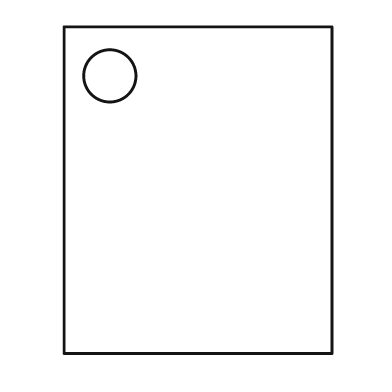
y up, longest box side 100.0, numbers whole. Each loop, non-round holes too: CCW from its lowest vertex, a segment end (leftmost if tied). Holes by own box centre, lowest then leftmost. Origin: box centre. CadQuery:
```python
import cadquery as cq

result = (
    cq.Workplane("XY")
    .moveTo(-41.0, -50.0)
    .lineTo(41.0, -50.0)
    .lineTo(41.0, 50.0)
    .lineTo(-41.0, 50.0)
    .close()
    .moveTo(-27.0, 35.0)
    .circle(8.0)
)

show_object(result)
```